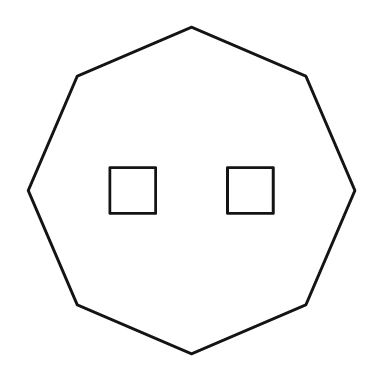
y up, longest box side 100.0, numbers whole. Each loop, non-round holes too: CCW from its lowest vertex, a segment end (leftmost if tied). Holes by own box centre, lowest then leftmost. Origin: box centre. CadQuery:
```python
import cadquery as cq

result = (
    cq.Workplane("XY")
    .moveTo(0.0, -50.0)
    .lineTo(35.0, -35.0)
    .lineTo(50.0, 0.0)
    .lineTo(35.0, 35.0)
    .lineTo(0.0, 50.0)
    .lineTo(-35.0, 35.0)
    .lineTo(-50.0, 0.0)
    .lineTo(-35.0, -35.0)
    .close()
    .moveTo(-25.0, -7.0)
    .lineTo(-11.0, -7.0)
    .lineTo(-11.0, 7.0)
    .lineTo(-25.0, 7.0)
    .close()
    .moveTo(11.0, -7.0)
    .lineTo(25.0, -7.0)
    .lineTo(25.0, 7.0)
    .lineTo(11.0, 7.0)
    .close()
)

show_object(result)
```